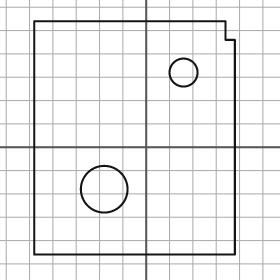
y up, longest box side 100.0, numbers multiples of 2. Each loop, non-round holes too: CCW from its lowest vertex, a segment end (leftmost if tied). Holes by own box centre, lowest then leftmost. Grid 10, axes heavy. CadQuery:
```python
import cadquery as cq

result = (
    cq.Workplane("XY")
    .moveTo(-48.0, -46.0)
    .lineTo(38.0, -46.0)
    .lineTo(38.0, 46.0)
    .lineTo(34.0, 46.0)
    .lineTo(34.0, 54.0)
    .lineTo(-48.0, 54.0)
    .close()
    .moveTo(-18.0, -18.0)
    .circle(10.0)
    .moveTo(16.0, 32.0)
    .circle(6.0)
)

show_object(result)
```